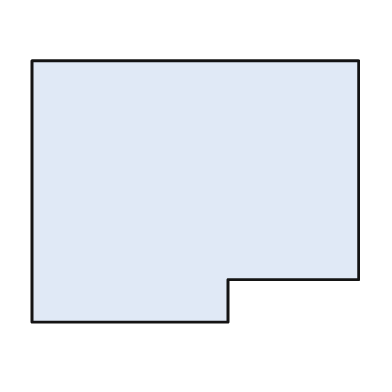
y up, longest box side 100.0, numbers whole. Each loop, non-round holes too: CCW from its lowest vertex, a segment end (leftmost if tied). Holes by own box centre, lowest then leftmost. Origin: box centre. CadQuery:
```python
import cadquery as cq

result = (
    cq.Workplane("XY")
    .moveTo(-50.0, -40.0)
    .lineTo(10.0, -40.0)
    .lineTo(10.0, -27.0)
    .lineTo(50.0, -27.0)
    .lineTo(50.0, 40.0)
    .lineTo(-50.0, 40.0)
    .close()
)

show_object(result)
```